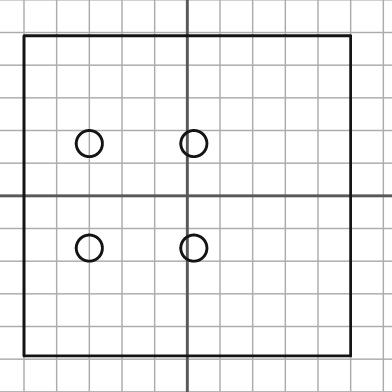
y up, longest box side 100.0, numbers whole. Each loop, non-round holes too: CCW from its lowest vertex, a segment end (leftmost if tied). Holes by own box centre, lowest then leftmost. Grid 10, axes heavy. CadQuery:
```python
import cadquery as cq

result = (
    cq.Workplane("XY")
    .moveTo(-50.0, -49.0)
    .lineTo(50.0, -49.0)
    .lineTo(50.0, 49.0)
    .lineTo(-50.0, 49.0)
    .close()
    .moveTo(-30.0, -16.0)
    .circle(4.0)
    .moveTo(2.0, -16.0)
    .circle(4.0)
    .moveTo(-30.0, 16.0)
    .circle(4.0)
    .moveTo(2.0, 16.0)
    .circle(4.0)
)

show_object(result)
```